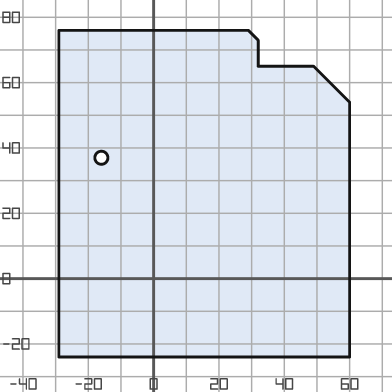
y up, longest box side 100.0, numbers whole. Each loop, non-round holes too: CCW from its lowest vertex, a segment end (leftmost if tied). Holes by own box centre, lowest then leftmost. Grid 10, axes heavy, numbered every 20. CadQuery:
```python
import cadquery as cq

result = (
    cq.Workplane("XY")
    .moveTo(-29.0, -24.0)
    .lineTo(60.0, -24.0)
    .lineTo(60.0, 54.0)
    .lineTo(49.0, 65.0)
    .lineTo(32.0, 65.0)
    .lineTo(32.0, 73.0)
    .lineTo(29.0, 76.0)
    .lineTo(-29.0, 76.0)
    .close()
    .moveTo(-16.0, 37.0)
    .circle(2.0)
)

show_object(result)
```